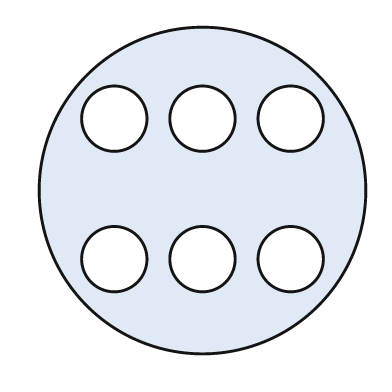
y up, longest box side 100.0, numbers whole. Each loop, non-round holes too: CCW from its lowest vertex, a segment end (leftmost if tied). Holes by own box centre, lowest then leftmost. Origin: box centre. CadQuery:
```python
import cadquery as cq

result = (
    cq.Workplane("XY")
    .moveTo(0.0, 0.0)
    .circle(50.0)
    .moveTo(-27.0, -21.0)
    .circle(10.0)
    .moveTo(0.0, -21.0)
    .circle(10.0)
    .moveTo(27.0, -21.0)
    .circle(10.0)
    .moveTo(-27.0, 22.0)
    .circle(10.0)
    .moveTo(0.0, 22.0)
    .circle(10.0)
    .moveTo(27.0, 22.0)
    .circle(10.0)
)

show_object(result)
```